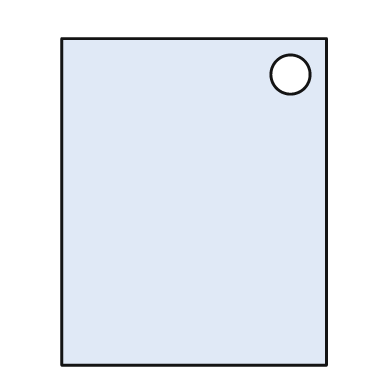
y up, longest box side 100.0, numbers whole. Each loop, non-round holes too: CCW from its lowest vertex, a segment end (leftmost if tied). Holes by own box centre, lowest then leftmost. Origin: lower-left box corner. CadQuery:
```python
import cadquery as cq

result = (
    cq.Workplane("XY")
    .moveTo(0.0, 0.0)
    .lineTo(81.0, 0.0)
    .lineTo(81.0, 100.0)
    .lineTo(0.0, 100.0)
    .close()
    .moveTo(70.0, 89.0)
    .circle(6.0)
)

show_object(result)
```